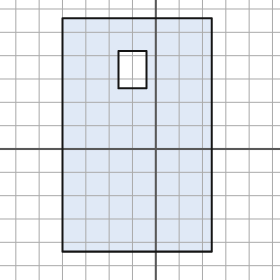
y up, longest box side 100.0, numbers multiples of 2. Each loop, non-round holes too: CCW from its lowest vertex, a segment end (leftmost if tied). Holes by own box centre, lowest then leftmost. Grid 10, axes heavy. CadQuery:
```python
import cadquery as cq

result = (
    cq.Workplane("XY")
    .moveTo(-40.0, -44.0)
    .lineTo(24.0, -44.0)
    .lineTo(24.0, 56.0)
    .lineTo(-40.0, 56.0)
    .close()
    .moveTo(-16.0, 26.0)
    .lineTo(-4.0, 26.0)
    .lineTo(-4.0, 42.0)
    .lineTo(-16.0, 42.0)
    .close()
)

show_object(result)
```